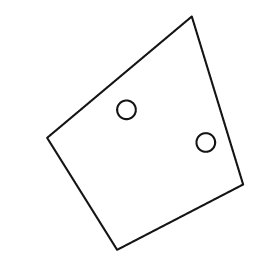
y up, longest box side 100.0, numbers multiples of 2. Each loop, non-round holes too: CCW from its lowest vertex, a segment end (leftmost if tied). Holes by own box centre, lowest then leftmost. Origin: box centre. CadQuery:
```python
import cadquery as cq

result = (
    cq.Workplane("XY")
    .moveTo(-12.0, -50.0)
    .lineTo(42.0, -22.0)
    .lineTo(20.0, 50.0)
    .lineTo(-42.0, -2.0)
    .close()
    .moveTo(26.0, -4.0)
    .circle(4.0)
    .moveTo(-8.0, 10.0)
    .circle(4.0)
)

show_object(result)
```